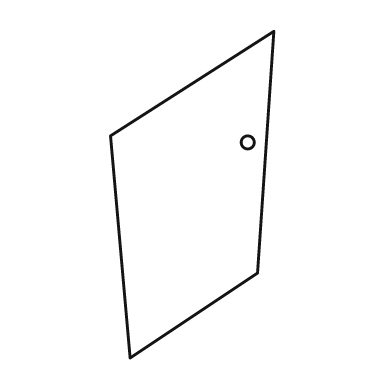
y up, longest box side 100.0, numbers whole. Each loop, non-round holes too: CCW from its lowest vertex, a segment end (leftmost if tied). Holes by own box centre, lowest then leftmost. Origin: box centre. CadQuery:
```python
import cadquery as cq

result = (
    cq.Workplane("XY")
    .moveTo(-19.0, -50.0)
    .lineTo(20.0, -24.0)
    .lineTo(25.0, 50.0)
    .lineTo(-25.0, 18.0)
    .close()
    .moveTo(17.0, 16.0)
    .circle(2.0)
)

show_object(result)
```